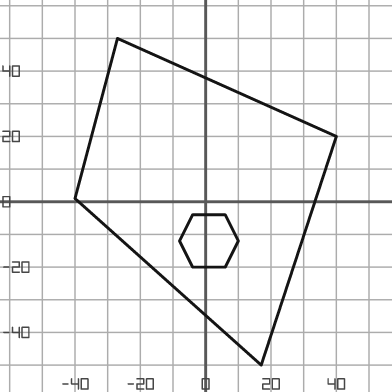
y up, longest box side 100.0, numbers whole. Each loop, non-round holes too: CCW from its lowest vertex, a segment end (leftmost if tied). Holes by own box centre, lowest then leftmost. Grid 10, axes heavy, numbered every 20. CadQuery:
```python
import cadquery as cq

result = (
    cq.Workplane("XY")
    .moveTo(17.0, -50.0)
    .lineTo(40.0, 20.0)
    .lineTo(-27.0, 50.0)
    .lineTo(-40.0, 1.0)
    .close()
    .moveTo(-4.0, -20.0)
    .lineTo(6.0, -20.0)
    .lineTo(10.0, -12.0)
    .lineTo(6.0, -4.0)
    .lineTo(-4.0, -4.0)
    .lineTo(-8.0, -12.0)
    .close()
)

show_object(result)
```